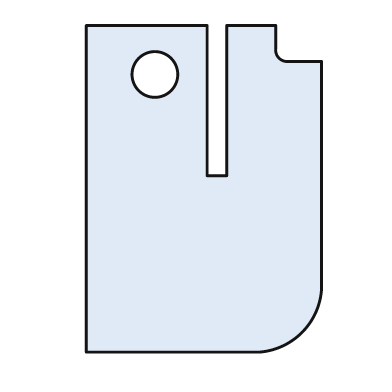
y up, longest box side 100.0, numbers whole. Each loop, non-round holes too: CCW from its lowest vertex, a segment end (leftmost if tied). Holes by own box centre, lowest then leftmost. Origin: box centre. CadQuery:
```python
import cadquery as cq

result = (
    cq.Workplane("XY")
    .moveTo(-36.0, -50.0)
    .lineTo(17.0, -50.0)
    .threePointArc((30.0, -44.0), (36.0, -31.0))
    .lineTo(36.0, 39.0)
    .lineTo(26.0, 39.0)
    .threePointArc((23.0, 40.0), (22.0, 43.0))
    .lineTo(22.0, 50.0)
    .lineTo(7.0, 50.0)
    .lineTo(7.0, 4.0)
    .lineTo(1.0, 4.0)
    .lineTo(1.0, 50.0)
    .lineTo(-36.0, 50.0)
    .close()
    .moveTo(-15.0, 35.0)
    .circle(7.0)
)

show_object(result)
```